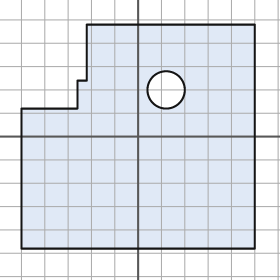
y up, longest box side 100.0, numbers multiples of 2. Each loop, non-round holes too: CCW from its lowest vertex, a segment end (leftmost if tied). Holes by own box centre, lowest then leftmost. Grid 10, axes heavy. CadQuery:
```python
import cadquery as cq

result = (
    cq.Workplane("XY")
    .moveTo(-50.0, -48.0)
    .lineTo(50.0, -48.0)
    .lineTo(50.0, 48.0)
    .lineTo(-22.0, 48.0)
    .lineTo(-22.0, 24.0)
    .lineTo(-26.0, 24.0)
    .lineTo(-26.0, 12.0)
    .lineTo(-50.0, 12.0)
    .close()
    .moveTo(12.0, 20.0)
    .circle(8.0)
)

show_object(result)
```